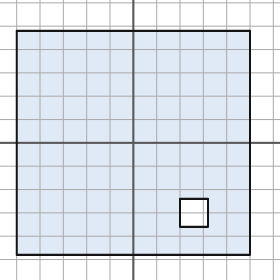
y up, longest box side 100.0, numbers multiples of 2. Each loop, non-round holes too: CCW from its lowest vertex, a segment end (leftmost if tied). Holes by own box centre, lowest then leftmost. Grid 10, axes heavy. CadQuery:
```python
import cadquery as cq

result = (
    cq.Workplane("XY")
    .moveTo(-50.0, -48.0)
    .lineTo(50.0, -48.0)
    .lineTo(50.0, 48.0)
    .lineTo(-50.0, 48.0)
    .close()
    .moveTo(20.0, -36.0)
    .lineTo(32.0, -36.0)
    .lineTo(32.0, -24.0)
    .lineTo(20.0, -24.0)
    .close()
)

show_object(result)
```